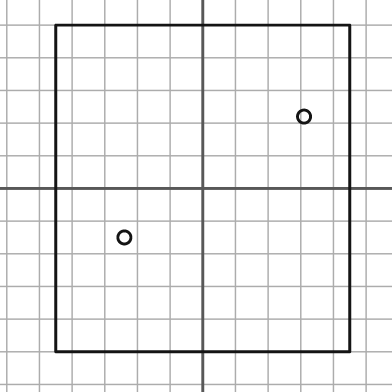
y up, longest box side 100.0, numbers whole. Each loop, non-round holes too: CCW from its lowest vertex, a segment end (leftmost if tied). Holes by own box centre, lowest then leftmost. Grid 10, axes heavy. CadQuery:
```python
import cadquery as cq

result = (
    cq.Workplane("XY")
    .moveTo(-45.0, -50.0)
    .lineTo(45.0, -50.0)
    .lineTo(45.0, 50.0)
    .lineTo(-45.0, 50.0)
    .close()
    .moveTo(-24.0, -15.0)
    .circle(2.0)
    .moveTo(31.0, 22.0)
    .circle(2.0)
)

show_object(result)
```